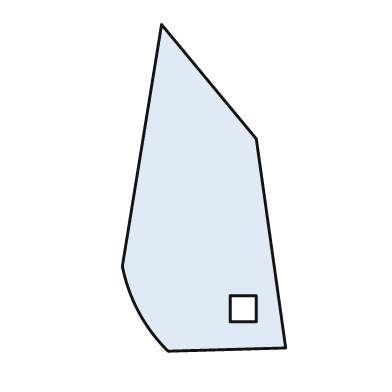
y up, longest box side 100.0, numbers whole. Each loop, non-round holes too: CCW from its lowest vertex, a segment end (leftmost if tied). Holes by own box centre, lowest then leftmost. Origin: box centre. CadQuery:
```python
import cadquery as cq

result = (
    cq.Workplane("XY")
    .moveTo(-11.0, -50.0)
    .lineTo(25.0, -49.0)
    .lineTo(16.0, 15.0)
    .lineTo(-13.0, 50.0)
    .lineTo(-25.0, -24.0)
    .threePointArc((-20.0, -38.0), (-11.0, -50.0))
    .close()
    .moveTo(8.0, -41.0)
    .lineTo(16.0, -41.0)
    .lineTo(16.0, -33.0)
    .lineTo(8.0, -33.0)
    .close()
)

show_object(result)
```